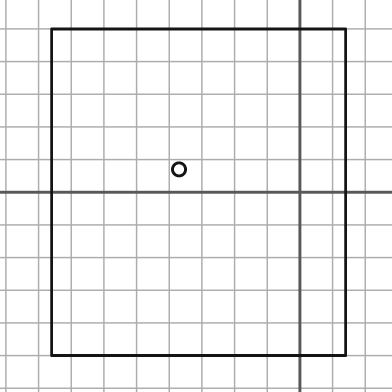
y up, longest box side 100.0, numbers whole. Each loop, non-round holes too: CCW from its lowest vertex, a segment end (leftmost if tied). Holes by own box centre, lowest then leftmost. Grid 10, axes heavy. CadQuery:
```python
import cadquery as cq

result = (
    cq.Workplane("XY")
    .moveTo(-76.0, -50.0)
    .lineTo(14.0, -50.0)
    .lineTo(14.0, 50.0)
    .lineTo(-76.0, 50.0)
    .close()
    .moveTo(-37.0, 7.0)
    .circle(2.0)
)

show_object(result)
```